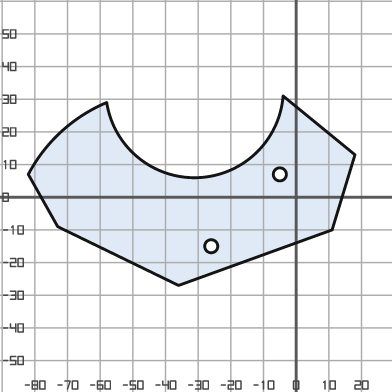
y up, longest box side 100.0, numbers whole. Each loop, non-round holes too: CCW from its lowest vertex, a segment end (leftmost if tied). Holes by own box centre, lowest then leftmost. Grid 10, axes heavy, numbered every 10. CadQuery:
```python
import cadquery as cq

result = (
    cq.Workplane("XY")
    .moveTo(-36.0, -27.0)
    .lineTo(11.0, -10.0)
    .lineTo(18.0, 13.0)
    .lineTo(-4.0, 31.0)
    .threePointArc((-30.0, 6.0), (-58.0, 29.0))
    .threePointArc((-72.0, 20.0), (-82.0, 7.0))
    .lineTo(-73.0, -9.0)
    .close()
    .moveTo(-26.0, -15.0)
    .circle(2.0)
    .moveTo(-5.0, 7.0)
    .circle(2.0)
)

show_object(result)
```